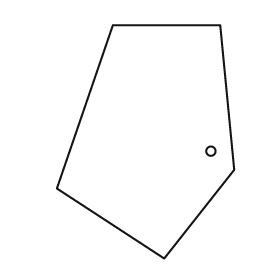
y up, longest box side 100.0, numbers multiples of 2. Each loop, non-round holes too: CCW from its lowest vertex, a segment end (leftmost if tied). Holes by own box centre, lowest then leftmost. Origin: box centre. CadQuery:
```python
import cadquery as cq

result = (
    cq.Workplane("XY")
    .moveTo(8.0, -50.0)
    .lineTo(38.0, -12.0)
    .lineTo(32.0, 50.0)
    .lineTo(-14.0, 50.0)
    .lineTo(-38.0, -20.0)
    .close()
    .moveTo(28.0, -4.0)
    .circle(2.0)
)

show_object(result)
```